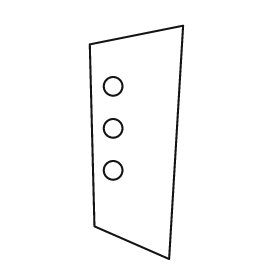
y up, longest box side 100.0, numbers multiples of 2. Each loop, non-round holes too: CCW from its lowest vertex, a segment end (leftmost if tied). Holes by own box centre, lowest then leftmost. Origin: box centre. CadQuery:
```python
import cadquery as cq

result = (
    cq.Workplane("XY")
    .moveTo(14.0, -50.0)
    .lineTo(20.0, 50.0)
    .lineTo(-20.0, 42.0)
    .lineTo(-18.0, -36.0)
    .close()
    .moveTo(-10.0, -12.0)
    .circle(4.0)
    .moveTo(-10.0, 6.0)
    .circle(4.0)
    .moveTo(-10.0, 24.0)
    .circle(4.0)
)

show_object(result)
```